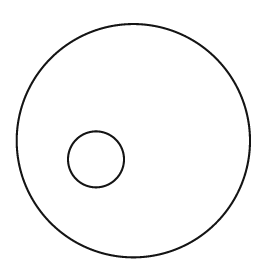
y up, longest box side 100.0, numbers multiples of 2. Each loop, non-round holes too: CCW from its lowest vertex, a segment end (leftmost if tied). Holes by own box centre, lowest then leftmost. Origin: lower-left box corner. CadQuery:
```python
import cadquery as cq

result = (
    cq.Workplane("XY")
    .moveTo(50.0, 50.0)
    .circle(50.0)
    .moveTo(34.0, 42.0)
    .circle(12.0)
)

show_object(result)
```